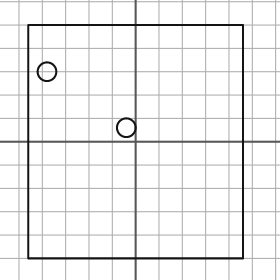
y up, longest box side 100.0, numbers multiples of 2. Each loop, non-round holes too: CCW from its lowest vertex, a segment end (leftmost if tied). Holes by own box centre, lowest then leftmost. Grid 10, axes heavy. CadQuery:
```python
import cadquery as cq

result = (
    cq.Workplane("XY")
    .moveTo(-46.0, -50.0)
    .lineTo(46.0, -50.0)
    .lineTo(46.0, 50.0)
    .lineTo(-46.0, 50.0)
    .close()
    .moveTo(-4.0, 6.0)
    .circle(4.0)
    .moveTo(-38.0, 30.0)
    .circle(4.0)
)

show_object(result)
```